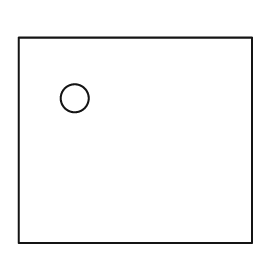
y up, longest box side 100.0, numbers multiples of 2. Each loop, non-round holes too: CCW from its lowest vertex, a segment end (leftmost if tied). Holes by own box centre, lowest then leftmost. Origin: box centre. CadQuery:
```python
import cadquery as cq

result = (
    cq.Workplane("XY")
    .moveTo(-50.0, -44.0)
    .lineTo(50.0, -44.0)
    .lineTo(50.0, 44.0)
    .lineTo(-50.0, 44.0)
    .close()
    .moveTo(-26.0, 18.0)
    .circle(6.0)
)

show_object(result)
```